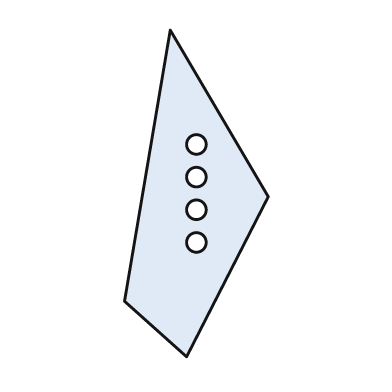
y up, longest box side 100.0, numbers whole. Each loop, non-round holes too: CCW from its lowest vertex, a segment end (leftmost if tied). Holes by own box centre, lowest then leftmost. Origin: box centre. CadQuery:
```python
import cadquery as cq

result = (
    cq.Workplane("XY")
    .moveTo(-3.0, -50.0)
    .lineTo(22.0, -1.0)
    .lineTo(-8.0, 50.0)
    .lineTo(-22.0, -33.0)
    .close()
    .moveTo(0.0, -15.0)
    .circle(3.0)
    .moveTo(0.0, -5.0)
    .circle(3.0)
    .moveTo(0.0, 5.0)
    .circle(3.0)
    .moveTo(0.0, 15.0)
    .circle(3.0)
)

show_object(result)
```